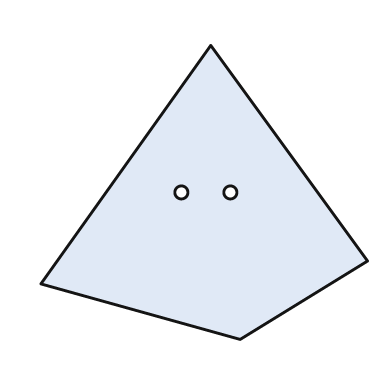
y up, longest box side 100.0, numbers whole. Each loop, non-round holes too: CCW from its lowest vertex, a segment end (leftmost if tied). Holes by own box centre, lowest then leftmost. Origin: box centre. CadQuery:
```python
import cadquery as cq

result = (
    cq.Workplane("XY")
    .moveTo(11.0, -45.0)
    .lineTo(50.0, -21.0)
    .lineTo(2.0, 45.0)
    .lineTo(-50.0, -28.0)
    .close()
    .moveTo(-7.0, 0.0)
    .circle(2.0)
    .moveTo(8.0, 0.0)
    .circle(2.0)
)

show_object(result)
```